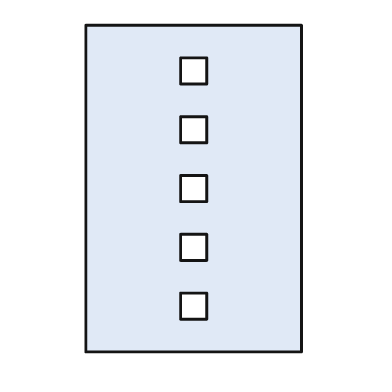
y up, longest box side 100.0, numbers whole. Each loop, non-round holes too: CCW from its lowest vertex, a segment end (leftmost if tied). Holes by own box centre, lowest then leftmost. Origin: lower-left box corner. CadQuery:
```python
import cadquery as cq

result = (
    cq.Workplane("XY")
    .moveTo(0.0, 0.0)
    .lineTo(66.0, 0.0)
    .lineTo(66.0, 100.0)
    .lineTo(0.0, 100.0)
    .close()
    .moveTo(29.0, 10.0)
    .lineTo(37.0, 10.0)
    .lineTo(37.0, 18.0)
    .lineTo(29.0, 18.0)
    .close()
    .moveTo(29.0, 28.0)
    .lineTo(37.0, 28.0)
    .lineTo(37.0, 36.0)
    .lineTo(29.0, 36.0)
    .close()
    .moveTo(29.0, 46.0)
    .lineTo(37.0, 46.0)
    .lineTo(37.0, 54.0)
    .lineTo(29.0, 54.0)
    .close()
    .moveTo(29.0, 64.0)
    .lineTo(37.0, 64.0)
    .lineTo(37.0, 72.0)
    .lineTo(29.0, 72.0)
    .close()
    .moveTo(29.0, 82.0)
    .lineTo(37.0, 82.0)
    .lineTo(37.0, 90.0)
    .lineTo(29.0, 90.0)
    .close()
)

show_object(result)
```